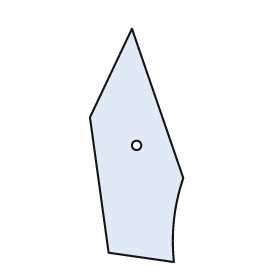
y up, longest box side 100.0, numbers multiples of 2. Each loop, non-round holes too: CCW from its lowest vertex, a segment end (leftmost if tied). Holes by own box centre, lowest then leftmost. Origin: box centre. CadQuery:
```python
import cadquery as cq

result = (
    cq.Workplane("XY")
    .moveTo(16.0, -50.0)
    .threePointArc((16.0, -32.0), (20.0, -14.0))
    .lineTo(-2.0, 50.0)
    .lineTo(-20.0, 12.0)
    .lineTo(-12.0, -46.0)
    .close()
    .moveTo(0.0, 0.0)
    .circle(2.0)
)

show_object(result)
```